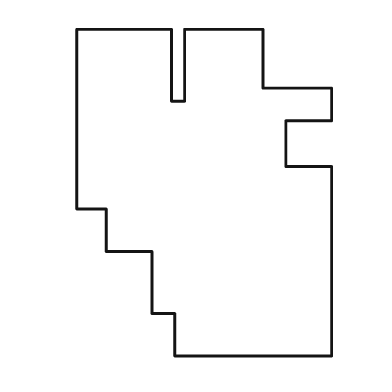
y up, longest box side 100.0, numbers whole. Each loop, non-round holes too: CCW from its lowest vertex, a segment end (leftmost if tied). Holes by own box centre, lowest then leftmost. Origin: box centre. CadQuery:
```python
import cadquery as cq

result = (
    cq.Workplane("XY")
    .moveTo(-9.0, -50.0)
    .lineTo(39.0, -50.0)
    .lineTo(39.0, 8.0)
    .lineTo(25.0, 8.0)
    .lineTo(25.0, 22.0)
    .lineTo(39.0, 22.0)
    .lineTo(39.0, 32.0)
    .lineTo(18.0, 32.0)
    .lineTo(18.0, 50.0)
    .lineTo(-6.0, 50.0)
    .lineTo(-6.0, 28.0)
    .lineTo(-10.0, 28.0)
    .lineTo(-10.0, 50.0)
    .lineTo(-39.0, 50.0)
    .lineTo(-39.0, -5.0)
    .lineTo(-30.0, -5.0)
    .lineTo(-30.0, -18.0)
    .lineTo(-16.0, -18.0)
    .lineTo(-16.0, -37.0)
    .lineTo(-9.0, -37.0)
    .close()
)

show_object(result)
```